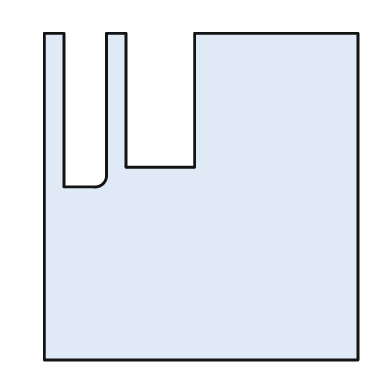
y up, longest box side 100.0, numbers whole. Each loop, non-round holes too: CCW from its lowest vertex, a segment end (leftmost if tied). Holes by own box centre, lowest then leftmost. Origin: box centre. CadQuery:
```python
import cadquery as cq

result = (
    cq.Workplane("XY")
    .moveTo(-48.0, -50.0)
    .lineTo(48.0, -50.0)
    .lineTo(48.0, 50.0)
    .lineTo(-2.0, 50.0)
    .lineTo(-2.0, 9.0)
    .lineTo(-23.0, 9.0)
    .lineTo(-23.0, 50.0)
    .lineTo(-29.0, 50.0)
    .lineTo(-29.0, 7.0)
    .threePointArc((-30.0, 4.0), (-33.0, 3.0))
    .lineTo(-42.0, 3.0)
    .lineTo(-42.0, 50.0)
    .lineTo(-48.0, 50.0)
    .close()
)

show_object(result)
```